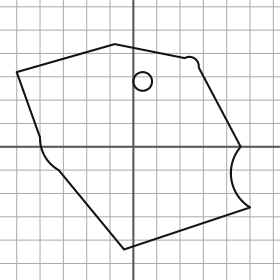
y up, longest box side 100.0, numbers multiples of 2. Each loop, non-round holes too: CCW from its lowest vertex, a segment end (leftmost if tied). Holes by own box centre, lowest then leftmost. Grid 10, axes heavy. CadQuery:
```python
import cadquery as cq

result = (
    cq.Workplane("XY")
    .moveTo(-4.0, -44.0)
    .lineTo(50.0, -26.0)
    .threePointArc((42.0, -14.0), (46.0, 0.0))
    .lineTo(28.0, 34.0)
    .threePointArc((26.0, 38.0), (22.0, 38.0))
    .lineTo(-8.0, 44.0)
    .lineTo(-50.0, 32.0)
    .lineTo(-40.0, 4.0)
    .threePointArc((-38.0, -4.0), (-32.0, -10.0))
    .close()
    .moveTo(4.0, 28.0)
    .circle(4.0)
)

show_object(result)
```